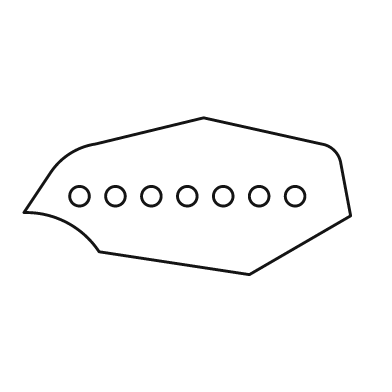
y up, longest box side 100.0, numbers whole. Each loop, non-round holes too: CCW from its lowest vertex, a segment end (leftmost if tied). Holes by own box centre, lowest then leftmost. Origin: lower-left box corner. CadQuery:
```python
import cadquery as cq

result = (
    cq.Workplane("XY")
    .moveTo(69.0, 0.0)
    .lineTo(100.0, 18.0)
    .lineTo(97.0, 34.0)
    .threePointArc((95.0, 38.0), (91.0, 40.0))
    .lineTo(55.0, 48.0)
    .lineTo(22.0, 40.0)
    .threePointArc((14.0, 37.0), (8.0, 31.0))
    .lineTo(0.0, 19.0)
    .threePointArc((13.0, 16.0), (23.0, 7.0))
    .close()
    .moveTo(17.0, 24.0)
    .circle(3.0)
    .moveTo(28.0, 24.0)
    .circle(3.0)
    .moveTo(39.0, 24.0)
    .circle(3.0)
    .moveTo(50.0, 24.0)
    .circle(3.0)
    .moveTo(61.0, 24.0)
    .circle(3.0)
    .moveTo(72.0, 24.0)
    .circle(3.0)
    .moveTo(83.0, 24.0)
    .circle(3.0)
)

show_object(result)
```